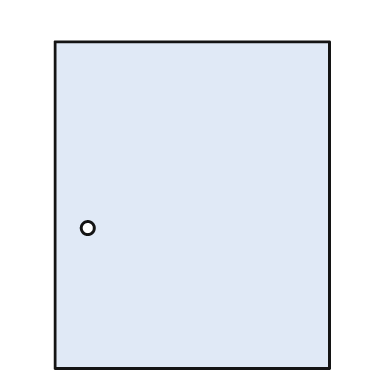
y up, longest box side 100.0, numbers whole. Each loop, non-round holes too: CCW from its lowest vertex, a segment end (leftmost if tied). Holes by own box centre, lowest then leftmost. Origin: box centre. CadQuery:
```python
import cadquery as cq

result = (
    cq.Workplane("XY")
    .moveTo(-42.0, -50.0)
    .lineTo(42.0, -50.0)
    .lineTo(42.0, 50.0)
    .lineTo(-42.0, 50.0)
    .close()
    .moveTo(-32.0, -7.0)
    .circle(2.0)
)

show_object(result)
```